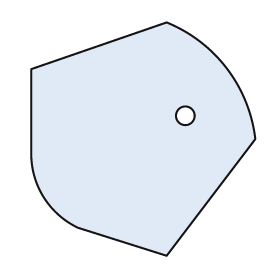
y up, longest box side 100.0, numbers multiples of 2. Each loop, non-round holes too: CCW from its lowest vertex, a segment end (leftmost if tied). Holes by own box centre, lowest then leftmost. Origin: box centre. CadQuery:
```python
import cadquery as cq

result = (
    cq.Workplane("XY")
    .moveTo(10.0, -50.0)
    .lineTo(48.0, 0.0)
    .threePointArc((36.0, 30.0), (10.0, 50.0))
    .lineTo(-48.0, 30.0)
    .lineTo(-48.0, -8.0)
    .threePointArc((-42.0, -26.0), (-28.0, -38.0))
    .close()
    .moveTo(18.0, 10.0)
    .circle(4.0)
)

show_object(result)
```